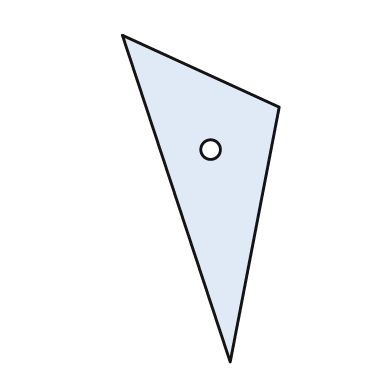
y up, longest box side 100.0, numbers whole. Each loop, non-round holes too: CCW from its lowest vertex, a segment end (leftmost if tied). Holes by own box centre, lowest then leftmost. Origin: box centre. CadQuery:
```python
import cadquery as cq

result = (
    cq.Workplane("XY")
    .moveTo(9.0, -50.0)
    .lineTo(24.0, 28.0)
    .lineTo(-24.0, 50.0)
    .close()
    .moveTo(3.0, 15.0)
    .circle(3.0)
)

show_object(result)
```